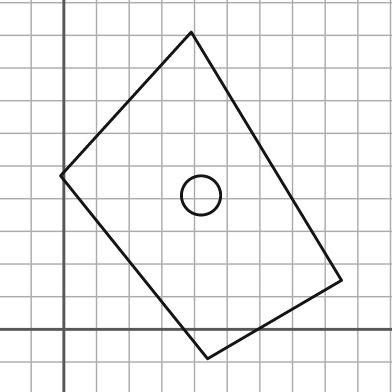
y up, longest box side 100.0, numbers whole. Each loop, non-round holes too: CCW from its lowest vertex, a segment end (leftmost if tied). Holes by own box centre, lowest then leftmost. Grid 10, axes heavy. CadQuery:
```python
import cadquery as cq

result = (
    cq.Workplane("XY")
    .moveTo(44.0, -9.0)
    .lineTo(85.0, 15.0)
    .lineTo(39.0, 91.0)
    .lineTo(-1.0, 47.0)
    .close()
    .moveTo(42.0, 41.0)
    .circle(6.0)
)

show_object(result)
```